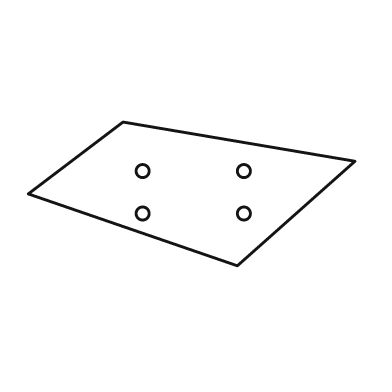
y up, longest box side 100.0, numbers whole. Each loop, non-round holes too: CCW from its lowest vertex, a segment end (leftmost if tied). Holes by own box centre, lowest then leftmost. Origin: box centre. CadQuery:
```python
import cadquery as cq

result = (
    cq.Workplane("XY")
    .moveTo(14.0, -22.0)
    .lineTo(50.0, 10.0)
    .lineTo(-21.0, 22.0)
    .lineTo(-50.0, 0.0)
    .close()
    .moveTo(-15.0, -6.0)
    .circle(2.0)
    .moveTo(16.0, -6.0)
    .circle(2.0)
    .moveTo(-15.0, 7.0)
    .circle(2.0)
    .moveTo(16.0, 7.0)
    .circle(2.0)
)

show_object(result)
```